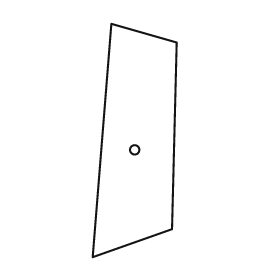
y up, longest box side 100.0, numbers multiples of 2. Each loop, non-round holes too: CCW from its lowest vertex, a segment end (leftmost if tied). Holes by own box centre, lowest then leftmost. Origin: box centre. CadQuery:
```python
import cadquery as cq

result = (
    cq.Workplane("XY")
    .moveTo(-18.0, -50.0)
    .lineTo(16.0, -38.0)
    .lineTo(18.0, 42.0)
    .lineTo(-10.0, 50.0)
    .close()
    .moveTo(0.0, -4.0)
    .circle(2.0)
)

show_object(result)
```